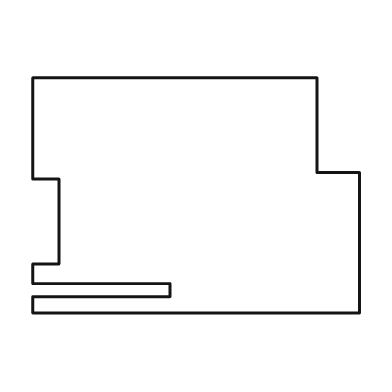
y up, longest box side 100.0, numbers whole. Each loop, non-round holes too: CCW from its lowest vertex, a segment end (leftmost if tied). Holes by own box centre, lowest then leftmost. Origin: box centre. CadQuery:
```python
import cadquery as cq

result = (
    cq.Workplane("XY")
    .moveTo(-50.0, -36.0)
    .lineTo(50.0, -36.0)
    .lineTo(50.0, 7.0)
    .lineTo(37.0, 7.0)
    .lineTo(37.0, 36.0)
    .lineTo(-50.0, 36.0)
    .lineTo(-50.0, 5.0)
    .lineTo(-42.0, 5.0)
    .lineTo(-42.0, -21.0)
    .lineTo(-50.0, -21.0)
    .lineTo(-50.0, -27.0)
    .lineTo(-8.0, -27.0)
    .lineTo(-8.0, -31.0)
    .lineTo(-50.0, -31.0)
    .close()
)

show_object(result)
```